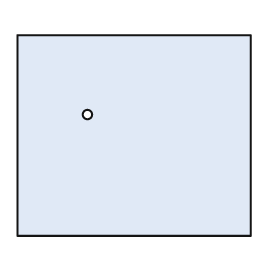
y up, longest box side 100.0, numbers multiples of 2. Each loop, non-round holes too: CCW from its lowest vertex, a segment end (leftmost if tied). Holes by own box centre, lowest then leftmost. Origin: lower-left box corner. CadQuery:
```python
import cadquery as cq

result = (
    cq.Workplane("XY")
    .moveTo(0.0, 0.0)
    .lineTo(100.0, 0.0)
    .lineTo(100.0, 86.0)
    .lineTo(0.0, 86.0)
    .close()
    .moveTo(30.0, 52.0)
    .circle(2.0)
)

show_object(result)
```